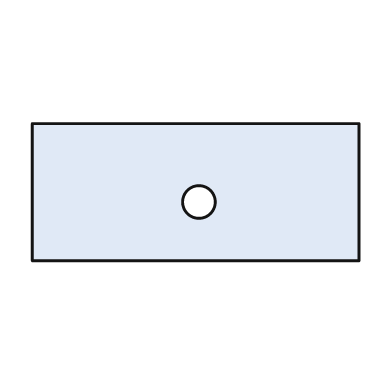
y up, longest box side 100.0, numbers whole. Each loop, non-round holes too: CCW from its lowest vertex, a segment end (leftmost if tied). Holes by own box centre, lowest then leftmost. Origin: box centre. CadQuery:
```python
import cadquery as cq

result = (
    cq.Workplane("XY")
    .moveTo(-50.0, -21.0)
    .lineTo(50.0, -21.0)
    .lineTo(50.0, 21.0)
    .lineTo(-50.0, 21.0)
    .close()
    .moveTo(1.0, -3.0)
    .circle(5.0)
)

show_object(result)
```